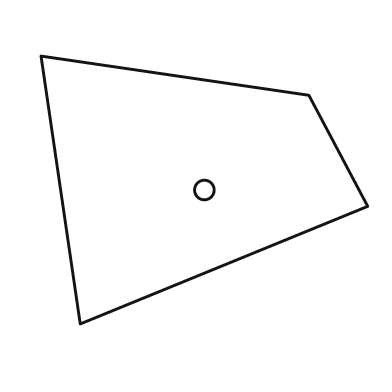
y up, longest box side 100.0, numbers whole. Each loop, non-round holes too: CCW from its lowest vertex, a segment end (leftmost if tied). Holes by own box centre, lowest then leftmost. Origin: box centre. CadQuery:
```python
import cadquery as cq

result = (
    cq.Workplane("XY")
    .moveTo(-38.0, -41.0)
    .lineTo(50.0, -5.0)
    .lineTo(32.0, 29.0)
    .lineTo(-50.0, 41.0)
    .close()
    .moveTo(0.0, 0.0)
    .circle(3.0)
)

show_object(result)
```